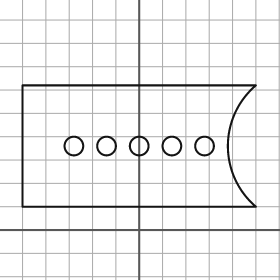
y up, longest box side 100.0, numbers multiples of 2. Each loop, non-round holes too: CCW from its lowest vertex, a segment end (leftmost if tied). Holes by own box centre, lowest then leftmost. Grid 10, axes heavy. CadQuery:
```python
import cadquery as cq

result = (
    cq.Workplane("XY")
    .moveTo(-50.0, 10.0)
    .lineTo(50.0, 10.0)
    .threePointArc((38.0, 36.0), (50.0, 62.0))
    .lineTo(-50.0, 62.0)
    .close()
    .moveTo(-28.0, 36.0)
    .circle(4.0)
    .moveTo(-14.0, 36.0)
    .circle(4.0)
    .moveTo(0.0, 36.0)
    .circle(4.0)
    .moveTo(14.0, 36.0)
    .circle(4.0)
    .moveTo(28.0, 36.0)
    .circle(4.0)
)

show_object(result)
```